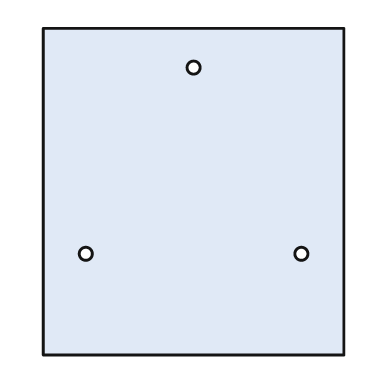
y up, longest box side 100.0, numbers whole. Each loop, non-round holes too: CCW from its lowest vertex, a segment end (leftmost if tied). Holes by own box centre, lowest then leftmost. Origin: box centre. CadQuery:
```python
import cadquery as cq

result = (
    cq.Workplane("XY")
    .moveTo(-46.0, -50.0)
    .lineTo(46.0, -50.0)
    .lineTo(46.0, 50.0)
    .lineTo(-46.0, 50.0)
    .close()
    .moveTo(-33.0, -19.0)
    .circle(2.0)
    .moveTo(33.0, -19.0)
    .circle(2.0)
    .moveTo(0.0, 38.0)
    .circle(2.0)
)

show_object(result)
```